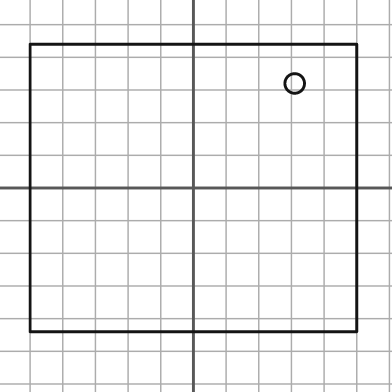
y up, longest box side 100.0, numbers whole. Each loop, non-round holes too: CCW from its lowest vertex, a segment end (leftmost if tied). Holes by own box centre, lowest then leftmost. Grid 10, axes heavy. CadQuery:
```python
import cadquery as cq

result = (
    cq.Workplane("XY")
    .moveTo(-50.0, -44.0)
    .lineTo(50.0, -44.0)
    .lineTo(50.0, 44.0)
    .lineTo(-50.0, 44.0)
    .close()
    .moveTo(31.0, 32.0)
    .circle(3.0)
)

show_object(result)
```